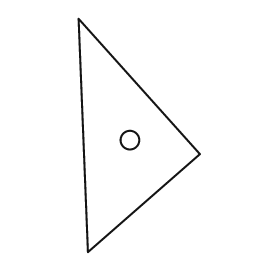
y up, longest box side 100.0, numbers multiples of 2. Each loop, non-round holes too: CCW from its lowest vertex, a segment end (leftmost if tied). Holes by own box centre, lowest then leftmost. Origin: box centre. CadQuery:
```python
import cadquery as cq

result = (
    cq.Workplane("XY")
    .moveTo(-22.0, -50.0)
    .lineTo(26.0, -8.0)
    .lineTo(-26.0, 50.0)
    .close()
    .moveTo(-4.0, -2.0)
    .circle(4.0)
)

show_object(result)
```